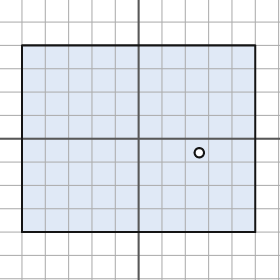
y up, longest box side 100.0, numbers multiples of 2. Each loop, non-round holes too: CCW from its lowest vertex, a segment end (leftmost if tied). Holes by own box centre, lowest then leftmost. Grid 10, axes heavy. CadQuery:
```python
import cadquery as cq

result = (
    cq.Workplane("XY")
    .moveTo(-50.0, -40.0)
    .lineTo(50.0, -40.0)
    .lineTo(50.0, 40.0)
    .lineTo(-50.0, 40.0)
    .close()
    .moveTo(26.0, -6.0)
    .circle(2.0)
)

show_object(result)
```